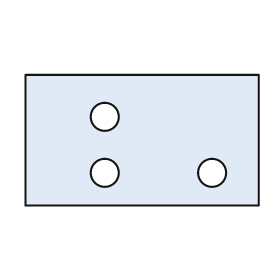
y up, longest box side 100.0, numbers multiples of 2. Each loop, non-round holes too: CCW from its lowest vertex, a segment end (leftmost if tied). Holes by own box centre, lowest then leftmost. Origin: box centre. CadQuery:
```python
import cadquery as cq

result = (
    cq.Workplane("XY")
    .moveTo(-50.0, -28.0)
    .lineTo(50.0, -28.0)
    .lineTo(50.0, 28.0)
    .lineTo(-50.0, 28.0)
    .close()
    .moveTo(-16.0, -14.0)
    .circle(6.0)
    .moveTo(30.0, -14.0)
    .circle(6.0)
    .moveTo(-16.0, 10.0)
    .circle(6.0)
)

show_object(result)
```